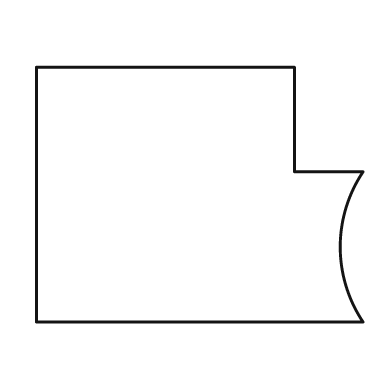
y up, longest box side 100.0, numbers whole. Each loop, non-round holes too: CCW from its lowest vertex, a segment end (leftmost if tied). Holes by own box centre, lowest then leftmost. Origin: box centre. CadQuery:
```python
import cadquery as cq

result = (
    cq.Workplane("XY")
    .moveTo(-50.0, -39.0)
    .lineTo(50.0, -39.0)
    .threePointArc((43.0, -16.0), (50.0, 7.0))
    .lineTo(29.0, 7.0)
    .lineTo(29.0, 39.0)
    .lineTo(-50.0, 39.0)
    .close()
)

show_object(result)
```